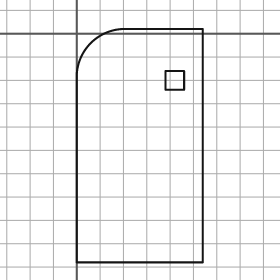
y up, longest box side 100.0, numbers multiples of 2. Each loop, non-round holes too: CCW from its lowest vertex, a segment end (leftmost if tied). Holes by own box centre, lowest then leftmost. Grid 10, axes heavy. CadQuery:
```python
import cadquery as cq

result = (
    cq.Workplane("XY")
    .moveTo(0.0, -98.0)
    .lineTo(54.0, -98.0)
    .lineTo(54.0, 2.0)
    .lineTo(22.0, 2.0)
    .threePointArc((6.0, -4.0), (0.0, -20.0))
    .close()
    .moveTo(38.0, -24.0)
    .lineTo(46.0, -24.0)
    .lineTo(46.0, -16.0)
    .lineTo(38.0, -16.0)
    .close()
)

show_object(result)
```